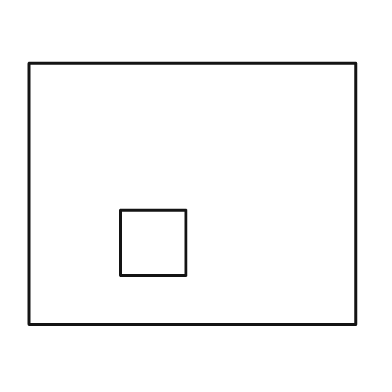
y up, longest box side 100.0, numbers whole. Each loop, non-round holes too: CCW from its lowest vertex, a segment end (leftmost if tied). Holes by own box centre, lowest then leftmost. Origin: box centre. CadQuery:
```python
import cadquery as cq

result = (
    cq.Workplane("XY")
    .moveTo(-50.0, -40.0)
    .lineTo(50.0, -40.0)
    .lineTo(50.0, 40.0)
    .lineTo(-50.0, 40.0)
    .close()
    .moveTo(-22.0, -25.0)
    .lineTo(-2.0, -25.0)
    .lineTo(-2.0, -5.0)
    .lineTo(-22.0, -5.0)
    .close()
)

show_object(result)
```